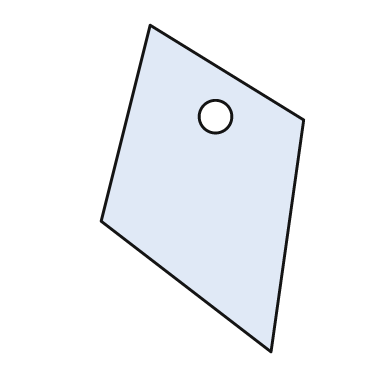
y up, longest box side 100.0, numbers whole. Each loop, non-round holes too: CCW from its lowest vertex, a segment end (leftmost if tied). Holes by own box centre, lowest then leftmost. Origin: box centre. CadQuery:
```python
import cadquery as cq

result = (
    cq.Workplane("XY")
    .moveTo(21.0, -50.0)
    .lineTo(31.0, 21.0)
    .lineTo(-16.0, 50.0)
    .lineTo(-31.0, -10.0)
    .close()
    .moveTo(4.0, 22.0)
    .circle(5.0)
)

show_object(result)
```